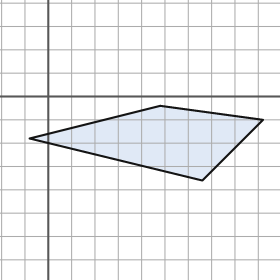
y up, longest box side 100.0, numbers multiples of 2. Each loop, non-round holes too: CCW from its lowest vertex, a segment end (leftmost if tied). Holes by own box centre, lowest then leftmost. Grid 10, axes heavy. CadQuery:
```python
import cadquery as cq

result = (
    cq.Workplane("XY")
    .moveTo(66.0, -36.0)
    .lineTo(92.0, -10.0)
    .lineTo(48.0, -4.0)
    .lineTo(-8.0, -18.0)
    .close()
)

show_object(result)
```